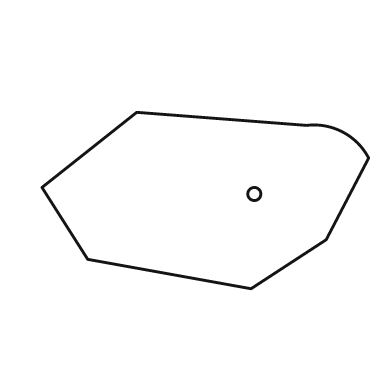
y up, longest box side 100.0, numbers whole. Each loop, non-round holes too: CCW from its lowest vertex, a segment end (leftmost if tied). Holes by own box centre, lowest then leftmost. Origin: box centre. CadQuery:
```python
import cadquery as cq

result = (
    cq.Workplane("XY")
    .moveTo(14.0, -27.0)
    .lineTo(37.0, -12.0)
    .lineTo(50.0, 13.0)
    .threePointArc((42.0, 21.0), (31.0, 23.0))
    .lineTo(-21.0, 27.0)
    .lineTo(-50.0, 4.0)
    .lineTo(-36.0, -18.0)
    .close()
    .moveTo(15.0, 2.0)
    .circle(2.0)
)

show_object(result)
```